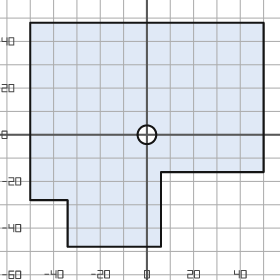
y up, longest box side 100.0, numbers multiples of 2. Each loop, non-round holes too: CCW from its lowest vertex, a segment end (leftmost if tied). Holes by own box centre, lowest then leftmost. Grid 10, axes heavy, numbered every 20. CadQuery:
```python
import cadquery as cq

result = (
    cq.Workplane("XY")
    .moveTo(-34.0, -48.0)
    .lineTo(6.0, -48.0)
    .lineTo(6.0, -16.0)
    .lineTo(50.0, -16.0)
    .lineTo(50.0, 48.0)
    .lineTo(-50.0, 48.0)
    .lineTo(-50.0, -28.0)
    .lineTo(-34.0, -28.0)
    .close()
    .moveTo(0.0, 0.0)
    .circle(4.0)
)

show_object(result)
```